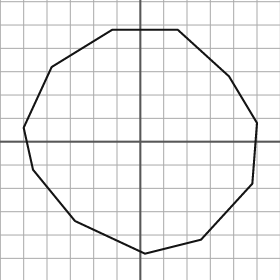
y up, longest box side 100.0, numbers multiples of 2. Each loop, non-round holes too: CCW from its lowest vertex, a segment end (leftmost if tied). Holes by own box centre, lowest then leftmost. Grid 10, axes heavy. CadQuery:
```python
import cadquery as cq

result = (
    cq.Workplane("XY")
    .moveTo(2.0, -48.0)
    .lineTo(26.0, -42.0)
    .lineTo(48.0, -18.0)
    .lineTo(50.0, 8.0)
    .lineTo(38.0, 28.0)
    .lineTo(16.0, 48.0)
    .lineTo(-12.0, 48.0)
    .lineTo(-38.0, 32.0)
    .lineTo(-50.0, 6.0)
    .lineTo(-46.0, -12.0)
    .lineTo(-28.0, -34.0)
    .close()
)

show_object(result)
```